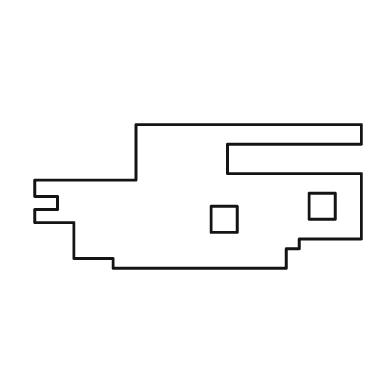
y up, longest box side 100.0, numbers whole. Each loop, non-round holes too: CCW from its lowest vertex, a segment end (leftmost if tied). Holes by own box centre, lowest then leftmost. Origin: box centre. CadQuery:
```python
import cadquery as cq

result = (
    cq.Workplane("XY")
    .moveTo(-26.0, -22.0)
    .lineTo(27.0, -22.0)
    .lineTo(27.0, -16.0)
    .lineTo(31.0, -16.0)
    .lineTo(31.0, -13.0)
    .lineTo(50.0, -13.0)
    .lineTo(50.0, 7.0)
    .lineTo(9.0, 7.0)
    .lineTo(9.0, 16.0)
    .lineTo(50.0, 16.0)
    .lineTo(50.0, 22.0)
    .lineTo(-19.0, 22.0)
    .lineTo(-19.0, 5.0)
    .lineTo(-50.0, 5.0)
    .lineTo(-50.0, 0.0)
    .lineTo(-43.0, 0.0)
    .lineTo(-43.0, -4.0)
    .lineTo(-50.0, -4.0)
    .lineTo(-50.0, -8.0)
    .lineTo(-38.0, -8.0)
    .lineTo(-38.0, -19.0)
    .lineTo(-26.0, -19.0)
    .close()
    .moveTo(4.0, -11.0)
    .lineTo(12.0, -11.0)
    .lineTo(12.0, -3.0)
    .lineTo(4.0, -3.0)
    .close()
    .moveTo(34.0, -7.0)
    .lineTo(42.0, -7.0)
    .lineTo(42.0, 1.0)
    .lineTo(34.0, 1.0)
    .close()
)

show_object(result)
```